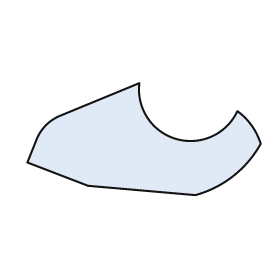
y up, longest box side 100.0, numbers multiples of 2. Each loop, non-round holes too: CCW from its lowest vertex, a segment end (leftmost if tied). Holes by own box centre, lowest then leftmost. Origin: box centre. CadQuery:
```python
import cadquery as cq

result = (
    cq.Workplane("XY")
    .moveTo(22.0, -24.0)
    .threePointArc((38.0, -16.0), (50.0, -2.0))
    .threePointArc((46.0, 6.0), (40.0, 12.0))
    .threePointArc((14.0, 0.0), (-2.0, 24.0))
    .lineTo(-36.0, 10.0)
    .threePointArc((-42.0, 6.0), (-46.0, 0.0))
    .lineTo(-50.0, -10.0)
    .lineTo(-24.0, -20.0)
    .close()
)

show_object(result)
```